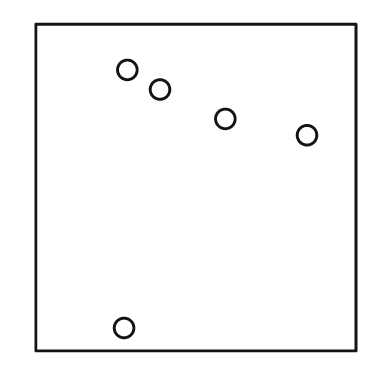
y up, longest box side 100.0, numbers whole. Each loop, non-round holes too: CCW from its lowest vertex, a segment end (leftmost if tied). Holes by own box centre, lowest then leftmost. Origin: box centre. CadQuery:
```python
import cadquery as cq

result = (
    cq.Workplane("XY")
    .moveTo(-49.0, -50.0)
    .lineTo(49.0, -50.0)
    .lineTo(49.0, 50.0)
    .lineTo(-49.0, 50.0)
    .close()
    .moveTo(-22.0, -43.0)
    .circle(3.0)
    .moveTo(34.0, 16.0)
    .circle(3.0)
    .moveTo(9.0, 21.0)
    .circle(3.0)
    .moveTo(-11.0, 30.0)
    .circle(3.0)
    .moveTo(-21.0, 36.0)
    .circle(3.0)
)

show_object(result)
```